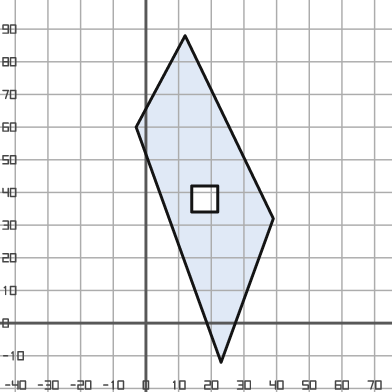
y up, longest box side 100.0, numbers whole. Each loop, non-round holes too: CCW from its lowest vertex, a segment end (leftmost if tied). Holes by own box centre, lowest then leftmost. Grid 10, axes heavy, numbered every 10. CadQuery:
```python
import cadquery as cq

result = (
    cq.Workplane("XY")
    .moveTo(23.0, -12.0)
    .lineTo(39.0, 32.0)
    .lineTo(12.0, 88.0)
    .lineTo(-3.0, 60.0)
    .close()
    .moveTo(14.0, 34.0)
    .lineTo(22.0, 34.0)
    .lineTo(22.0, 42.0)
    .lineTo(14.0, 42.0)
    .close()
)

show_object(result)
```